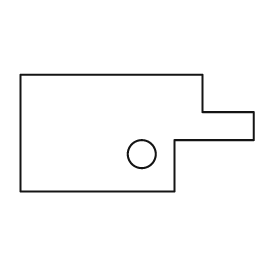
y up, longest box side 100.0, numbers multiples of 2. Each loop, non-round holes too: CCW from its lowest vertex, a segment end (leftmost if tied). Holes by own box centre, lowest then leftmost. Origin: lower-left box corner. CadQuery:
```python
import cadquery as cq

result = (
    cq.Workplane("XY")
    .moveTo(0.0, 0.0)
    .lineTo(66.0, 0.0)
    .lineTo(66.0, 22.0)
    .lineTo(100.0, 22.0)
    .lineTo(100.0, 34.0)
    .lineTo(78.0, 34.0)
    .lineTo(78.0, 50.0)
    .lineTo(0.0, 50.0)
    .close()
    .moveTo(52.0, 16.0)
    .circle(6.0)
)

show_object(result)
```